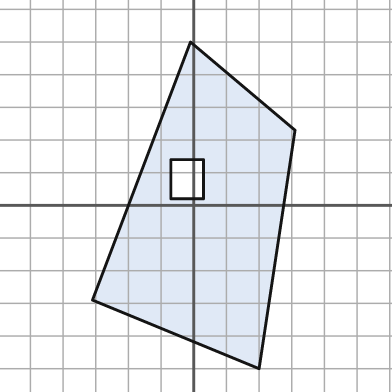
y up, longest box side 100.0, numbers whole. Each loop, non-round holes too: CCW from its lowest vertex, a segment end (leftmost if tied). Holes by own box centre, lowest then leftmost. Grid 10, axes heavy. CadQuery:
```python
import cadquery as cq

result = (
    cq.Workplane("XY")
    .moveTo(20.0, -50.0)
    .lineTo(31.0, 23.0)
    .lineTo(-1.0, 50.0)
    .lineTo(-31.0, -29.0)
    .close()
    .moveTo(-7.0, 2.0)
    .lineTo(3.0, 2.0)
    .lineTo(3.0, 14.0)
    .lineTo(-7.0, 14.0)
    .close()
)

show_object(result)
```